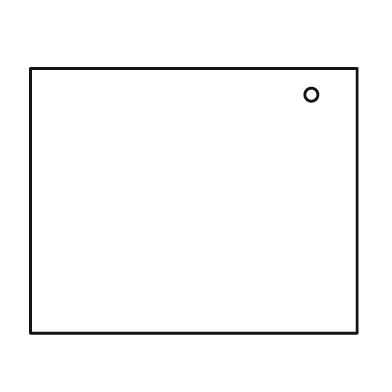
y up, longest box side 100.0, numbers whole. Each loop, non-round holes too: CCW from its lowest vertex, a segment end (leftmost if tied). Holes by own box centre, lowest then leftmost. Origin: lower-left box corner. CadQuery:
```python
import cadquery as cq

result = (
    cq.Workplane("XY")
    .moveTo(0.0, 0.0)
    .lineTo(100.0, 0.0)
    .lineTo(100.0, 81.0)
    .lineTo(0.0, 81.0)
    .close()
    .moveTo(86.0, 73.0)
    .circle(2.0)
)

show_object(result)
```